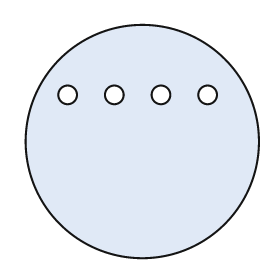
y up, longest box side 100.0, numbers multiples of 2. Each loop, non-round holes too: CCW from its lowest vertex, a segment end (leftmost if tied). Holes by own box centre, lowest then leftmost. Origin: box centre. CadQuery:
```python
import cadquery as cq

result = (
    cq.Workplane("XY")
    .moveTo(0.0, 0.0)
    .circle(50.0)
    .moveTo(-32.0, 20.0)
    .circle(4.0)
    .moveTo(-12.0, 20.0)
    .circle(4.0)
    .moveTo(8.0, 20.0)
    .circle(4.0)
    .moveTo(28.0, 20.0)
    .circle(4.0)
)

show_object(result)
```